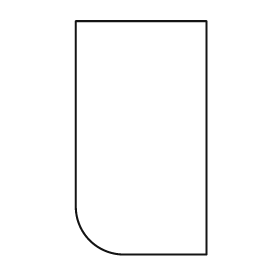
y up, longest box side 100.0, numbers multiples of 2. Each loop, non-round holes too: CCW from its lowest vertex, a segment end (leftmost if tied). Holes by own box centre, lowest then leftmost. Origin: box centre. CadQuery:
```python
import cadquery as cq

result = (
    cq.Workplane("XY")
    .moveTo(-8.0, -50.0)
    .lineTo(28.0, -50.0)
    .lineTo(28.0, 50.0)
    .lineTo(-28.0, 50.0)
    .lineTo(-28.0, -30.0)
    .threePointArc((-22.0, -44.0), (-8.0, -50.0))
    .close()
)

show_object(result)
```